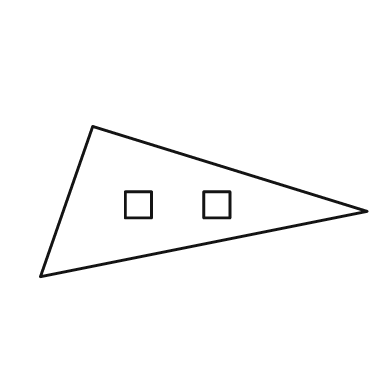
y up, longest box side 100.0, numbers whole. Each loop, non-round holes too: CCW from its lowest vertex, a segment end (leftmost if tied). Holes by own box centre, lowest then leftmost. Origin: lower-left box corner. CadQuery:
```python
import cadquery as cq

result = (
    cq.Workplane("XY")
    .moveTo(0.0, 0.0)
    .lineTo(100.0, 20.0)
    .lineTo(16.0, 46.0)
    .close()
    .moveTo(26.0, 18.0)
    .lineTo(34.0, 18.0)
    .lineTo(34.0, 26.0)
    .lineTo(26.0, 26.0)
    .close()
    .moveTo(50.0, 18.0)
    .lineTo(58.0, 18.0)
    .lineTo(58.0, 26.0)
    .lineTo(50.0, 26.0)
    .close()
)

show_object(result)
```